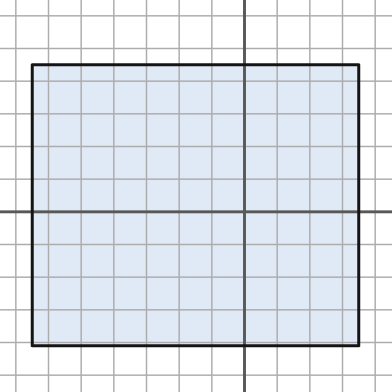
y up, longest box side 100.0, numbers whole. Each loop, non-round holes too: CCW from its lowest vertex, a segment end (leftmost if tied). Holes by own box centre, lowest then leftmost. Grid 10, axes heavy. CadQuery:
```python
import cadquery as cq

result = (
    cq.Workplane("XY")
    .moveTo(-65.0, -41.0)
    .lineTo(35.0, -41.0)
    .lineTo(35.0, 45.0)
    .lineTo(-65.0, 45.0)
    .close()
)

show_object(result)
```